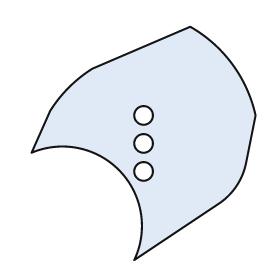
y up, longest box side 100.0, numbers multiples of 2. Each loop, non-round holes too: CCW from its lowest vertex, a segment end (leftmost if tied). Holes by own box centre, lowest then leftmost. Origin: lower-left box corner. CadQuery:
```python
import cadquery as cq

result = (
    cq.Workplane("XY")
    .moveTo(44.0, 0.0)
    .lineTo(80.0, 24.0)
    .threePointArc((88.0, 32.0), (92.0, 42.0))
    .lineTo(96.0, 62.0)
    .threePointArc((86.0, 84.0), (68.0, 100.0))
    .lineTo(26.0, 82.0)
    .threePointArc((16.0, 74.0), (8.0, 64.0))
    .lineTo(0.0, 46.0)
    .threePointArc((38.0, 38.0), (44.0, 0.0))
    .close()
    .moveTo(48.0, 38.0)
    .circle(4.0)
    .moveTo(48.0, 50.0)
    .circle(4.0)
    .moveTo(48.0, 62.0)
    .circle(4.0)
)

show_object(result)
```